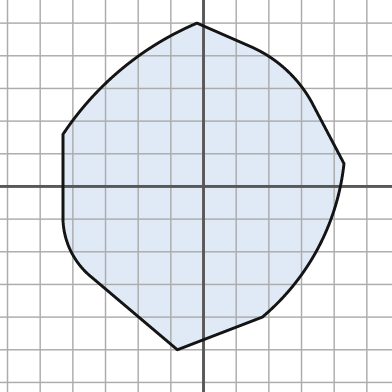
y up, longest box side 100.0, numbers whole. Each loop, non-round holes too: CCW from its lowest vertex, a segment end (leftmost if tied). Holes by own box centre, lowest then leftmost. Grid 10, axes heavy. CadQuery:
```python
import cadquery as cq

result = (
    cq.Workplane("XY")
    .moveTo(-8.0, -50.0)
    .lineTo(18.0, -40.0)
    .threePointArc((35.0, -19.0), (43.0, 7.0))
    .lineTo(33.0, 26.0)
    .threePointArc((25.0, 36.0), (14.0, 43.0))
    .lineTo(-2.0, 50.0)
    .threePointArc((-25.0, 36.0), (-43.0, 16.0))
    .lineTo(-43.0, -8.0)
    .threePointArc((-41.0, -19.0), (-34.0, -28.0))
    .close()
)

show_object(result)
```